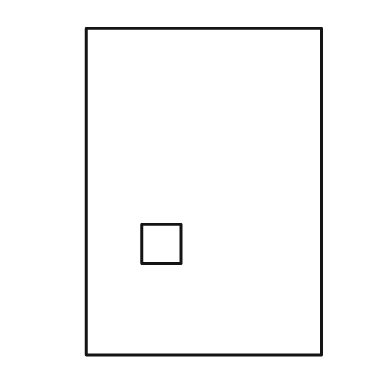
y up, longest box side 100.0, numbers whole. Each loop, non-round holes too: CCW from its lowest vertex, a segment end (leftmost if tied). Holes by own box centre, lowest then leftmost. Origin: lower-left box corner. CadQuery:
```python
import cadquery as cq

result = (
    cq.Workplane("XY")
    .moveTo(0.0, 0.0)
    .lineTo(72.0, 0.0)
    .lineTo(72.0, 100.0)
    .lineTo(0.0, 100.0)
    .close()
    .moveTo(17.0, 28.0)
    .lineTo(29.0, 28.0)
    .lineTo(29.0, 40.0)
    .lineTo(17.0, 40.0)
    .close()
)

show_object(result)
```